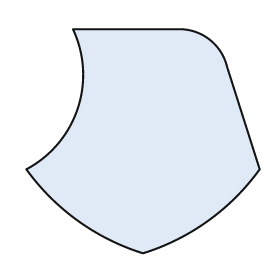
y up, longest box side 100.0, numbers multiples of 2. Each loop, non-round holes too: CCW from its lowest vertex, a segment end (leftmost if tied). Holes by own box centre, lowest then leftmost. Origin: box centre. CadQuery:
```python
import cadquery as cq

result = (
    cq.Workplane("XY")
    .moveTo(0.0, -48.0)
    .threePointArc((28.0, -34.0), (50.0, -12.0))
    .lineTo(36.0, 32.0)
    .threePointArc((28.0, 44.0), (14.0, 48.0))
    .lineTo(-30.0, 48.0)
    .threePointArc((-28.0, 14.0), (-50.0, -12.0))
    .threePointArc((-28.0, -34.0), (0.0, -48.0))
    .close()
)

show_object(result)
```